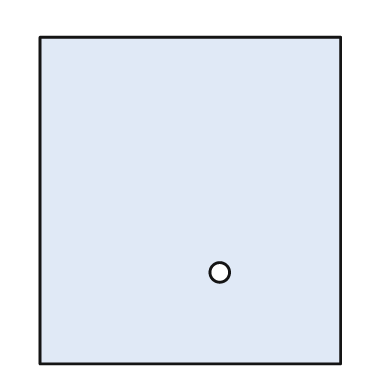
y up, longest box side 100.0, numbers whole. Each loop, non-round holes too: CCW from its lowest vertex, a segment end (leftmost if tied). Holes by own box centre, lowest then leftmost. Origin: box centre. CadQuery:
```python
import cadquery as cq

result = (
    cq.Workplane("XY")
    .moveTo(-46.0, -50.0)
    .lineTo(46.0, -50.0)
    .lineTo(46.0, 50.0)
    .lineTo(-46.0, 50.0)
    .close()
    .moveTo(9.0, -22.0)
    .circle(3.0)
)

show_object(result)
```